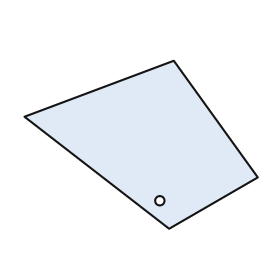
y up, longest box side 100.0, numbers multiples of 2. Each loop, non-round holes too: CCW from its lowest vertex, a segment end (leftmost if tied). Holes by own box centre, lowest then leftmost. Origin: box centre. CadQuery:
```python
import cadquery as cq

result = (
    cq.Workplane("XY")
    .moveTo(12.0, -36.0)
    .lineTo(50.0, -14.0)
    .lineTo(14.0, 36.0)
    .lineTo(-50.0, 12.0)
    .close()
    .moveTo(8.0, -24.0)
    .circle(2.0)
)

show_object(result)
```